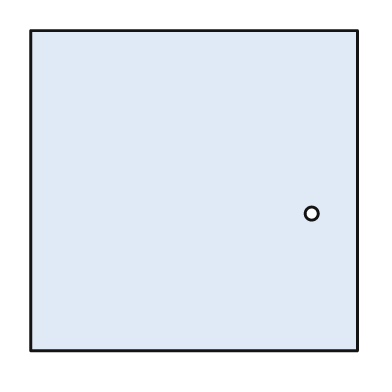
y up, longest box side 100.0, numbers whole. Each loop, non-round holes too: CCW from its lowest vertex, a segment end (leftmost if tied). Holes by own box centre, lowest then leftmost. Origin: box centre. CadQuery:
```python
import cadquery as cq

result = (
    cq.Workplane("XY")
    .moveTo(-50.0, -49.0)
    .lineTo(50.0, -49.0)
    .lineTo(50.0, 49.0)
    .lineTo(-50.0, 49.0)
    .close()
    .moveTo(36.0, -7.0)
    .circle(2.0)
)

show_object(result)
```